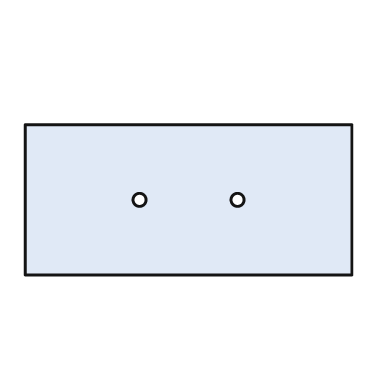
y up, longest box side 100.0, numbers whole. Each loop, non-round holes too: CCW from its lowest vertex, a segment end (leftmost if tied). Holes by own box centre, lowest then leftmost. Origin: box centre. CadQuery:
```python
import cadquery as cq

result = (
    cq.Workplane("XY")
    .moveTo(-50.0, -23.0)
    .lineTo(50.0, -23.0)
    .lineTo(50.0, 23.0)
    .lineTo(-50.0, 23.0)
    .close()
    .moveTo(-15.0, 0.0)
    .circle(2.0)
    .moveTo(15.0, 0.0)
    .circle(2.0)
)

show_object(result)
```